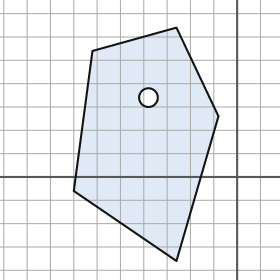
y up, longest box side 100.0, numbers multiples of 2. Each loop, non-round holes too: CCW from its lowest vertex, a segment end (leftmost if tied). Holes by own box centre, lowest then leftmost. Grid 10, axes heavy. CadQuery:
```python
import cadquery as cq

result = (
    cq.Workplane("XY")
    .moveTo(-26.0, -36.0)
    .lineTo(-8.0, 26.0)
    .lineTo(-26.0, 64.0)
    .lineTo(-62.0, 54.0)
    .lineTo(-70.0, -6.0)
    .close()
    .moveTo(-38.0, 34.0)
    .circle(4.0)
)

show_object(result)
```